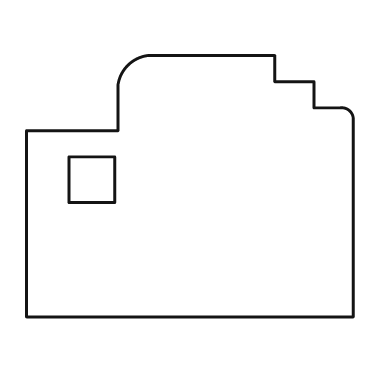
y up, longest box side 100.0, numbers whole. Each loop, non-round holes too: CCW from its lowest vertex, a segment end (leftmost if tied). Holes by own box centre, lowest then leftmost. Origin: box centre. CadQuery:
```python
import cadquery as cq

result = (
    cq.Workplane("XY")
    .moveTo(-50.0, -40.0)
    .lineTo(50.0, -40.0)
    .lineTo(50.0, 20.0)
    .threePointArc((49.0, 23.0), (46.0, 24.0))
    .lineTo(38.0, 24.0)
    .lineTo(38.0, 32.0)
    .lineTo(26.0, 32.0)
    .lineTo(26.0, 40.0)
    .lineTo(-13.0, 40.0)
    .threePointArc((-19.0, 37.0), (-22.0, 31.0))
    .lineTo(-22.0, 17.0)
    .lineTo(-50.0, 17.0)
    .close()
    .moveTo(-37.0, -5.0)
    .lineTo(-23.0, -5.0)
    .lineTo(-23.0, 9.0)
    .lineTo(-37.0, 9.0)
    .close()
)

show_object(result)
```